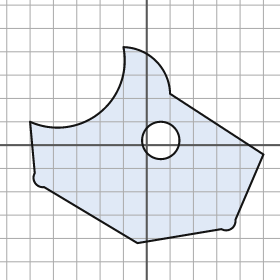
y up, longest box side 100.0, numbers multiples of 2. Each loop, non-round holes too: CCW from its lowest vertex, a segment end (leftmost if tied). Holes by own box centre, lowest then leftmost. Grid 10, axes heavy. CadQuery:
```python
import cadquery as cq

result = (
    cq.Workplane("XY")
    .moveTo(-4.0, -42.0)
    .lineTo(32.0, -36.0)
    .threePointArc((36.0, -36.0), (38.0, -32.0))
    .lineTo(50.0, -4.0)
    .lineTo(10.0, 22.0)
    .threePointArc((4.0, 36.0), (-10.0, 42.0))
    .threePointArc((-20.0, 14.0), (-50.0, 10.0))
    .lineTo(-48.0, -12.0)
    .threePointArc((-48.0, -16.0), (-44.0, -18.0))
    .close()
    .moveTo(6.0, 2.0)
    .circle(8.0)
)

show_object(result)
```